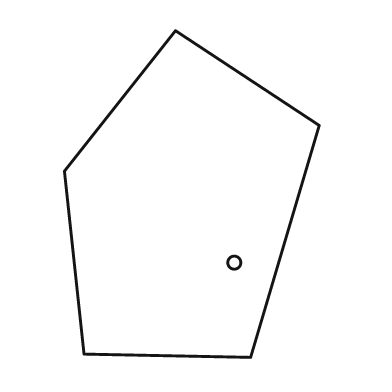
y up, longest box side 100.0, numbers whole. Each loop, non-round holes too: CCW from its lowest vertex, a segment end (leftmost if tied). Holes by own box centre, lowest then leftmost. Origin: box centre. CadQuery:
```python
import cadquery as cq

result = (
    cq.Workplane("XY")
    .moveTo(18.0, -50.0)
    .lineTo(39.0, 21.0)
    .lineTo(-5.0, 50.0)
    .lineTo(-39.0, 7.0)
    .lineTo(-33.0, -49.0)
    .close()
    .moveTo(13.0, -21.0)
    .circle(2.0)
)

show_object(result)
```